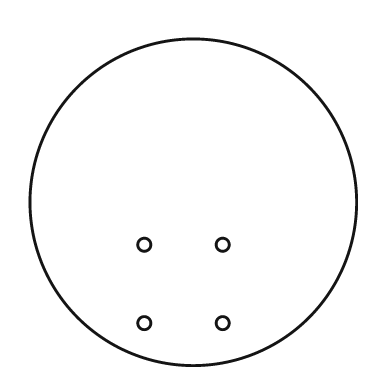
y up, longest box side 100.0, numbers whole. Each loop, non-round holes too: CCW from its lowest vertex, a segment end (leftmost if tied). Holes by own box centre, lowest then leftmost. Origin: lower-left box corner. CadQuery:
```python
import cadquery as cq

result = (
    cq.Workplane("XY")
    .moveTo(50.0, 50.0)
    .circle(50.0)
    .moveTo(35.0, 13.0)
    .circle(2.0)
    .moveTo(59.0, 13.0)
    .circle(2.0)
    .moveTo(35.0, 37.0)
    .circle(2.0)
    .moveTo(59.0, 37.0)
    .circle(2.0)
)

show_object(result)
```